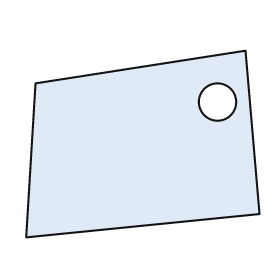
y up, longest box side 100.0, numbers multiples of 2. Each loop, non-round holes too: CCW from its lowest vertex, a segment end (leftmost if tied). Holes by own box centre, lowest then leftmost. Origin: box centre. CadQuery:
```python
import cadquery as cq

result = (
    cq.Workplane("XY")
    .moveTo(-50.0, -40.0)
    .lineTo(50.0, -30.0)
    .lineTo(44.0, 40.0)
    .lineTo(-46.0, 26.0)
    .close()
    .moveTo(32.0, 18.0)
    .circle(8.0)
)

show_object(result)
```